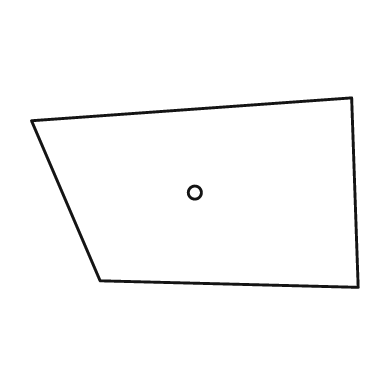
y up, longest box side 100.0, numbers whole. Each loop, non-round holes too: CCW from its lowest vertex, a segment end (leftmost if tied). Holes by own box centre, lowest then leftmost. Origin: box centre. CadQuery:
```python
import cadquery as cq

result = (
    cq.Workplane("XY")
    .moveTo(50.0, -29.0)
    .lineTo(48.0, 29.0)
    .lineTo(-50.0, 22.0)
    .lineTo(-29.0, -27.0)
    .close()
    .moveTo(0.0, 0.0)
    .circle(2.0)
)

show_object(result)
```